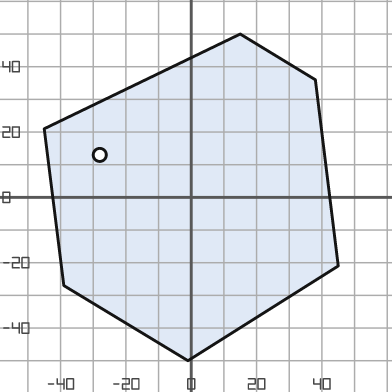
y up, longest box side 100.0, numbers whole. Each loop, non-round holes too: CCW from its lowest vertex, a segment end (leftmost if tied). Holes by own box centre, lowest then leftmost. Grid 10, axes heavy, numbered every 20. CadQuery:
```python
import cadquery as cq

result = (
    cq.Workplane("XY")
    .moveTo(-1.0, -50.0)
    .lineTo(45.0, -21.0)
    .lineTo(38.0, 36.0)
    .lineTo(15.0, 50.0)
    .lineTo(-45.0, 21.0)
    .lineTo(-39.0, -27.0)
    .close()
    .moveTo(-28.0, 13.0)
    .circle(2.0)
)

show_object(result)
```